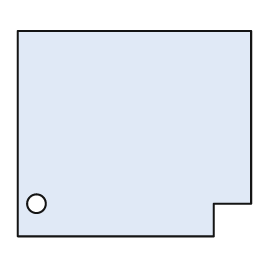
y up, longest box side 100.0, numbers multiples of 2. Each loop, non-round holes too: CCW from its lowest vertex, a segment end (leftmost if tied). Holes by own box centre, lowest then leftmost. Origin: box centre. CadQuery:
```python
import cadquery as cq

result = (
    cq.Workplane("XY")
    .moveTo(-50.0, -44.0)
    .lineTo(34.0, -44.0)
    .lineTo(34.0, -30.0)
    .lineTo(50.0, -30.0)
    .lineTo(50.0, 44.0)
    .lineTo(-50.0, 44.0)
    .close()
    .moveTo(-42.0, -30.0)
    .circle(4.0)
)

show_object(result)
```